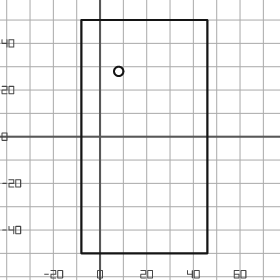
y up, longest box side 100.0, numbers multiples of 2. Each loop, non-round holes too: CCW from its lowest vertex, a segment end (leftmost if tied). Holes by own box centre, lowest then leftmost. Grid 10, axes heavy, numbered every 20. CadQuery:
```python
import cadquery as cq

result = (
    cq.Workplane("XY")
    .moveTo(-8.0, -50.0)
    .lineTo(46.0, -50.0)
    .lineTo(46.0, 50.0)
    .lineTo(-8.0, 50.0)
    .close()
    .moveTo(8.0, 28.0)
    .circle(2.0)
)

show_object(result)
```